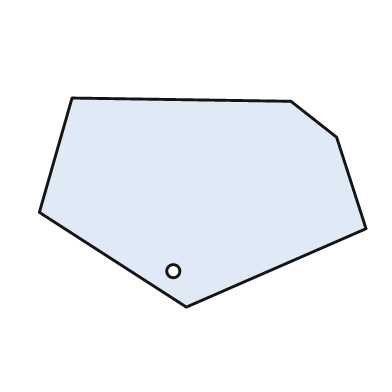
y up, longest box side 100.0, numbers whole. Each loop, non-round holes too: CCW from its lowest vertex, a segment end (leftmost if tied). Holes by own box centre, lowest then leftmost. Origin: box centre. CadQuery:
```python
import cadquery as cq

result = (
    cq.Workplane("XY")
    .moveTo(-5.0, -32.0)
    .lineTo(50.0, -8.0)
    .lineTo(41.0, 20.0)
    .lineTo(27.0, 31.0)
    .lineTo(-40.0, 32.0)
    .lineTo(-50.0, -3.0)
    .close()
    .moveTo(-9.0, -21.0)
    .circle(2.0)
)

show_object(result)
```